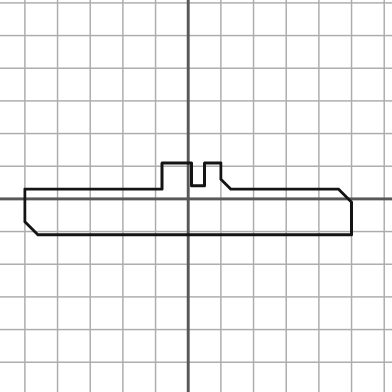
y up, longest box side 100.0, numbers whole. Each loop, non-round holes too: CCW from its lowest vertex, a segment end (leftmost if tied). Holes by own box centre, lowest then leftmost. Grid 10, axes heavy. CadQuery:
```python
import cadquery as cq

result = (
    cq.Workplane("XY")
    .moveTo(-46.0, -11.0)
    .lineTo(50.0, -11.0)
    .lineTo(50.0, -1.0)
    .lineTo(46.0, 3.0)
    .lineTo(13.0, 3.0)
    .lineTo(10.0, 6.0)
    .lineTo(10.0, 11.0)
    .lineTo(5.0, 11.0)
    .lineTo(5.0, 4.0)
    .lineTo(1.0, 4.0)
    .lineTo(1.0, 11.0)
    .lineTo(-8.0, 11.0)
    .lineTo(-8.0, 3.0)
    .lineTo(-50.0, 3.0)
    .lineTo(-50.0, -7.0)
    .close()
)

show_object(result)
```